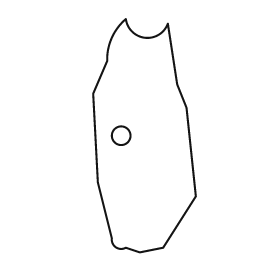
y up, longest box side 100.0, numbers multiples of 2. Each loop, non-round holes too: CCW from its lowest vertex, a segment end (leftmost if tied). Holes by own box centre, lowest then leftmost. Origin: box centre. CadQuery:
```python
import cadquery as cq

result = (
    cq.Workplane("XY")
    .moveTo(-2.0, -50.0)
    .lineTo(8.0, -48.0)
    .lineTo(22.0, -26.0)
    .lineTo(18.0, 12.0)
    .lineTo(14.0, 22.0)
    .lineTo(10.0, 48.0)
    .threePointArc((0.0, 42.0), (-8.0, 50.0))
    .threePointArc((-14.0, 42.0), (-16.0, 32.0))
    .lineTo(-22.0, 18.0)
    .lineTo(-20.0, -20.0)
    .lineTo(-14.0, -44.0)
    .threePointArc((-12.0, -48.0), (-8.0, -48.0))
    .close()
    .moveTo(-10.0, 0.0)
    .circle(4.0)
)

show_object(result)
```